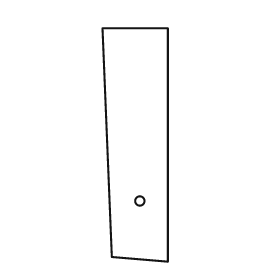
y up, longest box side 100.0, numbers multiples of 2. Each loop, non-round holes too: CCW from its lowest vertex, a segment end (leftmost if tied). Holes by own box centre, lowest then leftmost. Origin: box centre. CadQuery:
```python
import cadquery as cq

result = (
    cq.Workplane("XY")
    .moveTo(14.0, -50.0)
    .lineTo(14.0, 50.0)
    .lineTo(-14.0, 50.0)
    .lineTo(-10.0, -48.0)
    .close()
    .moveTo(2.0, -24.0)
    .circle(2.0)
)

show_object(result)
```